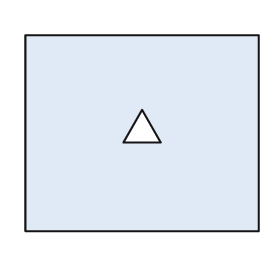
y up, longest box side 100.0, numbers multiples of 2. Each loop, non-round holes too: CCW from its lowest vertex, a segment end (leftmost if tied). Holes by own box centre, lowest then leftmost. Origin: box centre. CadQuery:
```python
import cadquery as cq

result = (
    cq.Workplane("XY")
    .moveTo(-50.0, -42.0)
    .lineTo(50.0, -42.0)
    .lineTo(50.0, 42.0)
    .lineTo(-50.0, 42.0)
    .close()
    .moveTo(-8.0, -4.0)
    .lineTo(8.0, -4.0)
    .lineTo(0.0, 10.0)
    .close()
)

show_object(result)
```